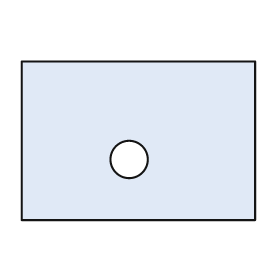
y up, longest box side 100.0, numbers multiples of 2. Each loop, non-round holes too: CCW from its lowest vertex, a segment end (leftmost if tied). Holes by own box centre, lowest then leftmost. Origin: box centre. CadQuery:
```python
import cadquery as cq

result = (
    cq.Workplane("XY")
    .moveTo(-50.0, -34.0)
    .lineTo(50.0, -34.0)
    .lineTo(50.0, 34.0)
    .lineTo(-50.0, 34.0)
    .close()
    .moveTo(-4.0, -8.0)
    .circle(8.0)
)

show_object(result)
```